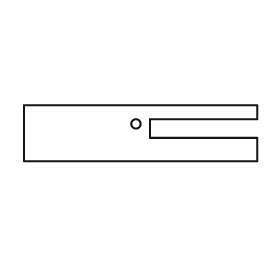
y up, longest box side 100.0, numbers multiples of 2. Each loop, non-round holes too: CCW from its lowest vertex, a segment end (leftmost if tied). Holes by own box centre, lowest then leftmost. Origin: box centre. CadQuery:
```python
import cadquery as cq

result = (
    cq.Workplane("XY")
    .moveTo(-50.0, -12.0)
    .lineTo(50.0, -12.0)
    .lineTo(50.0, -2.0)
    .lineTo(4.0, -2.0)
    .lineTo(4.0, 6.0)
    .lineTo(50.0, 6.0)
    .lineTo(50.0, 12.0)
    .lineTo(-50.0, 12.0)
    .close()
    .moveTo(-2.0, 4.0)
    .circle(2.0)
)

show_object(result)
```